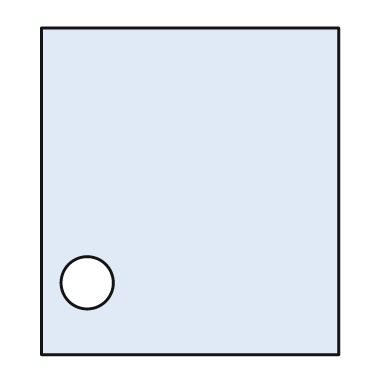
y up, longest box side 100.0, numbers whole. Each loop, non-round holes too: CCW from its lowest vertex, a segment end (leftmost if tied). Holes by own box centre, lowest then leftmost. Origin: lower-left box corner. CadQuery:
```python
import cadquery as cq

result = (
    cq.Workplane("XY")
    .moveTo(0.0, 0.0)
    .lineTo(91.0, 0.0)
    .lineTo(91.0, 100.0)
    .lineTo(0.0, 100.0)
    .close()
    .moveTo(14.0, 22.0)
    .circle(8.0)
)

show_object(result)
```